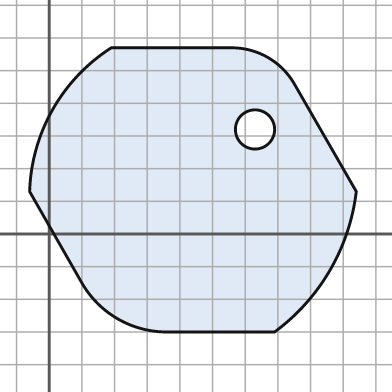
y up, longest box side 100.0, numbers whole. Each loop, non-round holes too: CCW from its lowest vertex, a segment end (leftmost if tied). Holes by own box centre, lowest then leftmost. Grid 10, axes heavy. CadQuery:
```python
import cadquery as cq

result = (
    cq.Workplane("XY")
    .moveTo(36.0, -30.0)
    .lineTo(69.0, -30.0)
    .threePointArc((86.0, -11.0), (94.0, 13.0))
    .lineTo(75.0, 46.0)
    .threePointArc((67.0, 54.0), (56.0, 57.0))
    .lineTo(19.0, 57.0)
    .threePointArc((1.0, 38.0), (-6.0, 13.0))
    .lineTo(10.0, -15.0)
    .threePointArc((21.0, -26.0), (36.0, -30.0))
    .close()
    .moveTo(63.0, 32.0)
    .circle(6.0)
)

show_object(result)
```